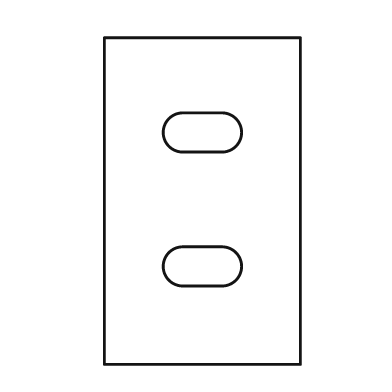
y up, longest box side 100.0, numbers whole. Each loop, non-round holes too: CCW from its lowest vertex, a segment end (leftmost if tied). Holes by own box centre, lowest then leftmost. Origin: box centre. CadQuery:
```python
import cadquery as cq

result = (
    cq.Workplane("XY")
    .moveTo(-30.0, -50.0)
    .lineTo(30.0, -50.0)
    .lineTo(30.0, 50.0)
    .lineTo(-30.0, 50.0)
    .close()
    .moveTo(-6.0, -26.0)
    .lineTo(6.0, -26.0)
    .threePointArc((12.0, -20.0), (6.0, -14.0))
    .lineTo(-6.0, -14.0)
    .threePointArc((-12.0, -20.0), (-6.0, -26.0))
    .close()
    .moveTo(-6.0, 15.0)
    .lineTo(6.0, 15.0)
    .threePointArc((12.0, 21.0), (6.0, 27.0))
    .lineTo(-6.0, 27.0)
    .threePointArc((-12.0, 21.0), (-6.0, 15.0))
    .close()
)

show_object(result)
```